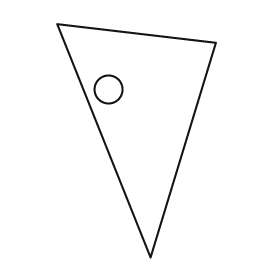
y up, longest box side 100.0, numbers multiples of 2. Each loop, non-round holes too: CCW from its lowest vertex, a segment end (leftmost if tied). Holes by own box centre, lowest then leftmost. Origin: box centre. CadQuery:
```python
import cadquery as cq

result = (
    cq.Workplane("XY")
    .moveTo(6.0, -50.0)
    .lineTo(34.0, 42.0)
    .lineTo(-34.0, 50.0)
    .close()
    .moveTo(-12.0, 22.0)
    .circle(6.0)
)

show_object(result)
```